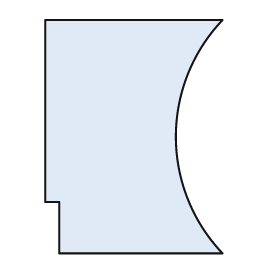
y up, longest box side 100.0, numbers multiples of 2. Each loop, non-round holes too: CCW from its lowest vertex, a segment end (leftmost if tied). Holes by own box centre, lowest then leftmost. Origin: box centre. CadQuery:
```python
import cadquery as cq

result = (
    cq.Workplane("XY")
    .moveTo(-32.0, -50.0)
    .lineTo(38.0, -50.0)
    .threePointArc((18.0, 0.0), (38.0, 50.0))
    .lineTo(-38.0, 50.0)
    .lineTo(-38.0, -28.0)
    .lineTo(-32.0, -28.0)
    .close()
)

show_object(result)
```